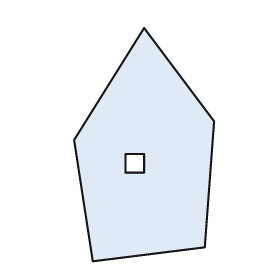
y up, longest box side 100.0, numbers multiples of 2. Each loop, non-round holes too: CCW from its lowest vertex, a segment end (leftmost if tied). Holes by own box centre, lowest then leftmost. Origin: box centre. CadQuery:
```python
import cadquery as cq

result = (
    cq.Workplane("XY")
    .moveTo(-22.0, -50.0)
    .lineTo(26.0, -44.0)
    .lineTo(30.0, 10.0)
    .lineTo(0.0, 50.0)
    .lineTo(-30.0, 2.0)
    .close()
    .moveTo(-8.0, -12.0)
    .lineTo(0.0, -12.0)
    .lineTo(0.0, -4.0)
    .lineTo(-8.0, -4.0)
    .close()
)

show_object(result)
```